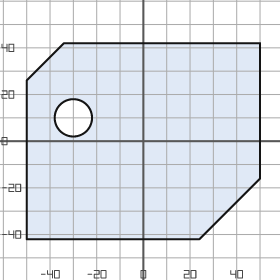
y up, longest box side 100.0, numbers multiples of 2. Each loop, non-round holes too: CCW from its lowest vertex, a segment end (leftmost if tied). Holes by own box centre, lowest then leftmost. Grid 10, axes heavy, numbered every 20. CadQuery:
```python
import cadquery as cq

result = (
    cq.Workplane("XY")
    .moveTo(-50.0, -42.0)
    .lineTo(24.0, -42.0)
    .lineTo(50.0, -16.0)
    .lineTo(50.0, 42.0)
    .lineTo(-34.0, 42.0)
    .lineTo(-50.0, 26.0)
    .close()
    .moveTo(-30.0, 10.0)
    .circle(8.0)
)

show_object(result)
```